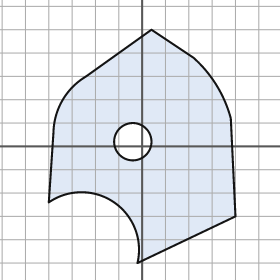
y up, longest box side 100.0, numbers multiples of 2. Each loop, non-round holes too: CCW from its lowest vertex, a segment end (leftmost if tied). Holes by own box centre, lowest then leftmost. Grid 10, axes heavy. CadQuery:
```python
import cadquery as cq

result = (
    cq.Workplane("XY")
    .moveTo(-2.0, -50.0)
    .lineTo(40.0, -30.0)
    .lineTo(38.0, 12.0)
    .threePointArc((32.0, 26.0), (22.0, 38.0))
    .lineTo(4.0, 50.0)
    .lineTo(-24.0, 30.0)
    .threePointArc((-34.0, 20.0), (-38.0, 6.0))
    .lineTo(-40.0, -24.0)
    .threePointArc((-12.0, -24.0), (-2.0, -50.0))
    .close()
    .moveTo(-4.0, 2.0)
    .circle(8.0)
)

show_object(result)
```